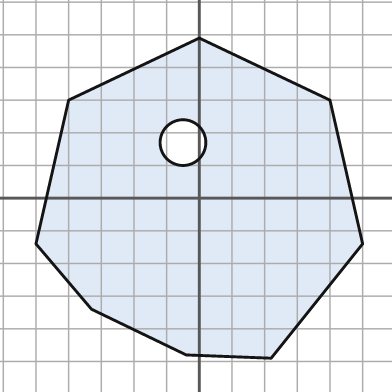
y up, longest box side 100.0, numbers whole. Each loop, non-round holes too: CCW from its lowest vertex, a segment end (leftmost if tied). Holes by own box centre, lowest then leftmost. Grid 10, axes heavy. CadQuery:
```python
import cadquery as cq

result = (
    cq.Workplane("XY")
    .moveTo(22.0, -49.0)
    .lineTo(50.0, -14.0)
    .lineTo(40.0, 30.0)
    .lineTo(0.0, 49.0)
    .lineTo(-40.0, 30.0)
    .lineTo(-50.0, -14.0)
    .lineTo(-33.0, -34.0)
    .lineTo(-4.0, -48.0)
    .close()
    .moveTo(-5.0, 17.0)
    .circle(7.0)
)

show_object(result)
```